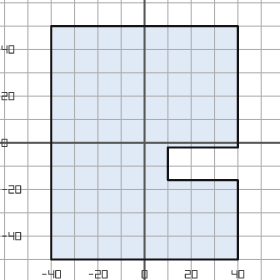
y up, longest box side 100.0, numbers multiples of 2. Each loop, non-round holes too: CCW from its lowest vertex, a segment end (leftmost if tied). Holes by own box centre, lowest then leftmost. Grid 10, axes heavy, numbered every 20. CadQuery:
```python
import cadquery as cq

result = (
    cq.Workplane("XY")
    .moveTo(-40.0, -50.0)
    .lineTo(40.0, -50.0)
    .lineTo(40.0, -16.0)
    .lineTo(10.0, -16.0)
    .lineTo(10.0, -2.0)
    .lineTo(40.0, -2.0)
    .lineTo(40.0, 50.0)
    .lineTo(-40.0, 50.0)
    .close()
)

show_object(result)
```